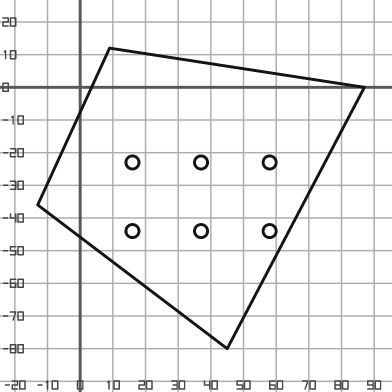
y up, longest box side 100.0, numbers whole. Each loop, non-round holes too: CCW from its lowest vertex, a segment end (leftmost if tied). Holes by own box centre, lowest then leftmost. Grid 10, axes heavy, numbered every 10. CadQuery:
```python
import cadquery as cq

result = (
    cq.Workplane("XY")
    .moveTo(45.0, -80.0)
    .lineTo(87.0, 0.0)
    .lineTo(9.0, 12.0)
    .lineTo(-13.0, -36.0)
    .close()
    .moveTo(16.0, -44.0)
    .circle(2.0)
    .moveTo(37.0, -44.0)
    .circle(2.0)
    .moveTo(58.0, -44.0)
    .circle(2.0)
    .moveTo(16.0, -23.0)
    .circle(2.0)
    .moveTo(37.0, -23.0)
    .circle(2.0)
    .moveTo(58.0, -23.0)
    .circle(2.0)
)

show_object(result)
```